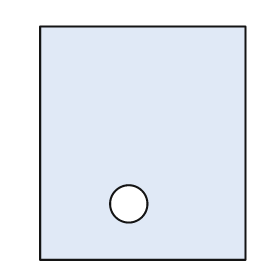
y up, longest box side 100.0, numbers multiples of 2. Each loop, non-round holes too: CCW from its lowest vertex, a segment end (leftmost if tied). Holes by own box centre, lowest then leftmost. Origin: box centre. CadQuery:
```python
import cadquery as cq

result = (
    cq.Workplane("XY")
    .moveTo(-44.0, -50.0)
    .lineTo(44.0, -50.0)
    .lineTo(44.0, 50.0)
    .lineTo(-44.0, 50.0)
    .close()
    .moveTo(-6.0, -26.0)
    .circle(8.0)
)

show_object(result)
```